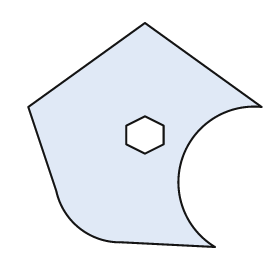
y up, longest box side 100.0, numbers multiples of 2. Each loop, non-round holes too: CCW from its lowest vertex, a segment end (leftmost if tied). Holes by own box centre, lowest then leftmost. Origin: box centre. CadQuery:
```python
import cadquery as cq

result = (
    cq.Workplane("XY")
    .moveTo(30.0, -48.0)
    .threePointArc((16.0, -10.0), (50.0, 12.0))
    .lineTo(0.0, 48.0)
    .lineTo(-50.0, 12.0)
    .lineTo(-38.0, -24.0)
    .threePointArc((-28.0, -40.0), (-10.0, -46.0))
    .close()
    .moveTo(0.0, -8.0)
    .lineTo(8.0, -4.0)
    .lineTo(8.0, 4.0)
    .lineTo(0.0, 8.0)
    .lineTo(-8.0, 4.0)
    .lineTo(-8.0, -4.0)
    .close()
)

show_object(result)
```